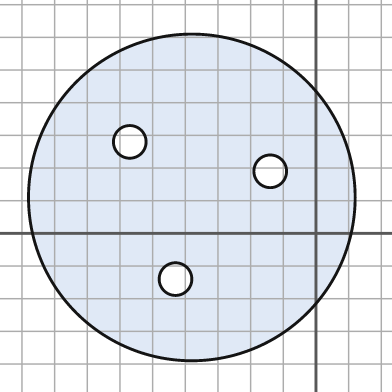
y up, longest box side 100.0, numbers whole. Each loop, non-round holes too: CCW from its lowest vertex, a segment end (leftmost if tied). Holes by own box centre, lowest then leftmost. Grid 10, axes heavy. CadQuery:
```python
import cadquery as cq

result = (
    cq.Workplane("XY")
    .moveTo(-38.0, 11.0)
    .circle(50.0)
    .moveTo(-43.0, -14.0)
    .circle(5.0)
    .moveTo(-14.0, 19.0)
    .circle(5.0)
    .moveTo(-57.0, 28.0)
    .circle(5.0)
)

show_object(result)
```